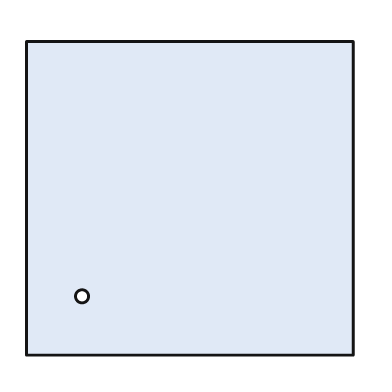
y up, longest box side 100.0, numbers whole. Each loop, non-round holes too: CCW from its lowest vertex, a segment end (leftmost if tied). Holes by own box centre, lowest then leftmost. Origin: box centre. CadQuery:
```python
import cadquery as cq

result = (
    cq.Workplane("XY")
    .moveTo(-50.0, -48.0)
    .lineTo(50.0, -48.0)
    .lineTo(50.0, 48.0)
    .lineTo(-50.0, 48.0)
    .close()
    .moveTo(-33.0, -30.0)
    .circle(2.0)
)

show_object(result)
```